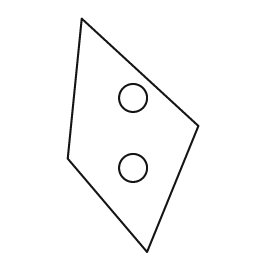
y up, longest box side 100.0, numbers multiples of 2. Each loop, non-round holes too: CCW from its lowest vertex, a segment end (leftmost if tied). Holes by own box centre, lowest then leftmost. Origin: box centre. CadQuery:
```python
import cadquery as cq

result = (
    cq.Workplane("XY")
    .moveTo(6.0, -50.0)
    .lineTo(28.0, 4.0)
    .lineTo(-22.0, 50.0)
    .lineTo(-28.0, -10.0)
    .close()
    .moveTo(0.0, -14.0)
    .circle(6.0)
    .moveTo(0.0, 16.0)
    .circle(6.0)
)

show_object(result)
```